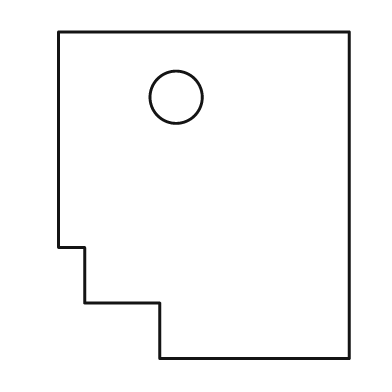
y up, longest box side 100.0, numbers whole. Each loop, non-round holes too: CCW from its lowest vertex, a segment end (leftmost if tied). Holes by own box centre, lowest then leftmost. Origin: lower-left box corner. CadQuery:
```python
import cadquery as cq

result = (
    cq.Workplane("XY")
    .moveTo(31.0, 0.0)
    .lineTo(89.0, 0.0)
    .lineTo(89.0, 100.0)
    .lineTo(0.0, 100.0)
    .lineTo(0.0, 34.0)
    .lineTo(8.0, 34.0)
    .lineTo(8.0, 17.0)
    .lineTo(31.0, 17.0)
    .close()
    .moveTo(36.0, 80.0)
    .circle(8.0)
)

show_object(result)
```